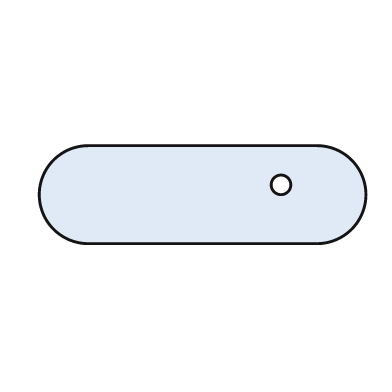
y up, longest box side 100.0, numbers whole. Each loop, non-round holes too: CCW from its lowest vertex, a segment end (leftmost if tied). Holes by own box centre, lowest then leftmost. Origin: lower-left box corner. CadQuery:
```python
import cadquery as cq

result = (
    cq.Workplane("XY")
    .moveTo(15.0, 0.0)
    .lineTo(85.0, 0.0)
    .threePointArc((100.0, 15.0), (85.0, 30.0))
    .lineTo(15.0, 30.0)
    .threePointArc((0.0, 15.0), (15.0, 0.0))
    .close()
    .moveTo(74.0, 18.0)
    .circle(3.0)
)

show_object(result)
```